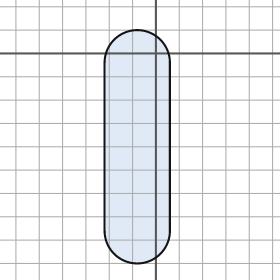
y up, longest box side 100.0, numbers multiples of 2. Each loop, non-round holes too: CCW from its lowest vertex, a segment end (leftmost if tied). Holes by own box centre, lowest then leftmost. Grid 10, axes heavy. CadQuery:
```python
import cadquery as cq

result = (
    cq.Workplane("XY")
    .moveTo(-22.0, -76.0)
    .threePointArc((-8.0, -90.0), (6.0, -76.0))
    .lineTo(6.0, -4.0)
    .threePointArc((-8.0, 10.0), (-22.0, -4.0))
    .close()
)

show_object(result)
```